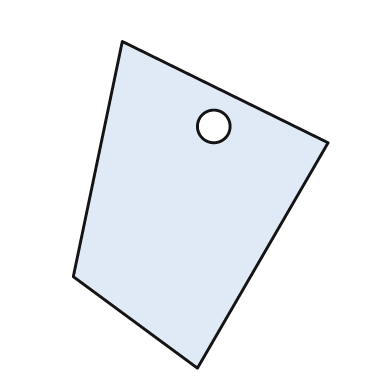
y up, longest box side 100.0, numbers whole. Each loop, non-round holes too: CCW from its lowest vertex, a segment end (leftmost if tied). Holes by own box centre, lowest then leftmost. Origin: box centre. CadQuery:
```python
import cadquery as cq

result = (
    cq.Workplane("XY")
    .moveTo(-1.0, -50.0)
    .lineTo(39.0, 19.0)
    .lineTo(-24.0, 50.0)
    .lineTo(-39.0, -22.0)
    .close()
    .moveTo(4.0, 24.0)
    .circle(5.0)
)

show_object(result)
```